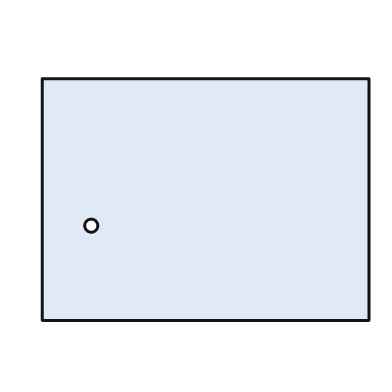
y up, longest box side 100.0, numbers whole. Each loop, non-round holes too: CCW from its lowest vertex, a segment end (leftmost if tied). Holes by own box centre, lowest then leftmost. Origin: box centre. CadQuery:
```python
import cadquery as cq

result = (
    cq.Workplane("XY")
    .moveTo(-50.0, -37.0)
    .lineTo(50.0, -37.0)
    .lineTo(50.0, 37.0)
    .lineTo(-50.0, 37.0)
    .close()
    .moveTo(-35.0, -8.0)
    .circle(2.0)
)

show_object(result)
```